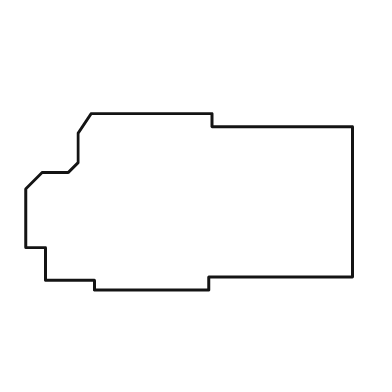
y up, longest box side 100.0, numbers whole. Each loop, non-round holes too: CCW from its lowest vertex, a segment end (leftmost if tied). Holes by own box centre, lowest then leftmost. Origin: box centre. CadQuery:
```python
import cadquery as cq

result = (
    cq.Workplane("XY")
    .moveTo(-29.0, -27.0)
    .lineTo(6.0, -27.0)
    .lineTo(6.0, -23.0)
    .lineTo(50.0, -23.0)
    .lineTo(50.0, 23.0)
    .lineTo(7.0, 23.0)
    .lineTo(7.0, 27.0)
    .lineTo(-30.0, 27.0)
    .lineTo(-34.0, 21.0)
    .lineTo(-34.0, 12.0)
    .lineTo(-37.0, 9.0)
    .lineTo(-45.0, 9.0)
    .lineTo(-50.0, 4.0)
    .lineTo(-50.0, -14.0)
    .lineTo(-44.0, -14.0)
    .lineTo(-44.0, -24.0)
    .lineTo(-29.0, -24.0)
    .close()
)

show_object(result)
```